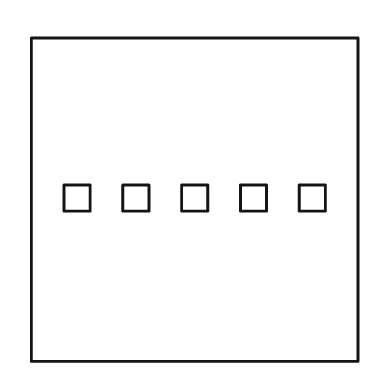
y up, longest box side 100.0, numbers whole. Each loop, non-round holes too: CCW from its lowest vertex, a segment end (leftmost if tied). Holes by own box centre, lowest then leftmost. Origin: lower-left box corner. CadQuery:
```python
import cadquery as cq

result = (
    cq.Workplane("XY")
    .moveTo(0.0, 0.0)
    .lineTo(100.0, 0.0)
    .lineTo(100.0, 99.0)
    .lineTo(0.0, 99.0)
    .close()
    .moveTo(10.0, 46.0)
    .lineTo(18.0, 46.0)
    .lineTo(18.0, 54.0)
    .lineTo(10.0, 54.0)
    .close()
    .moveTo(28.0, 46.0)
    .lineTo(36.0, 46.0)
    .lineTo(36.0, 54.0)
    .lineTo(28.0, 54.0)
    .close()
    .moveTo(46.0, 46.0)
    .lineTo(54.0, 46.0)
    .lineTo(54.0, 54.0)
    .lineTo(46.0, 54.0)
    .close()
    .moveTo(64.0, 46.0)
    .lineTo(72.0, 46.0)
    .lineTo(72.0, 54.0)
    .lineTo(64.0, 54.0)
    .close()
    .moveTo(82.0, 46.0)
    .lineTo(90.0, 46.0)
    .lineTo(90.0, 54.0)
    .lineTo(82.0, 54.0)
    .close()
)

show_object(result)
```